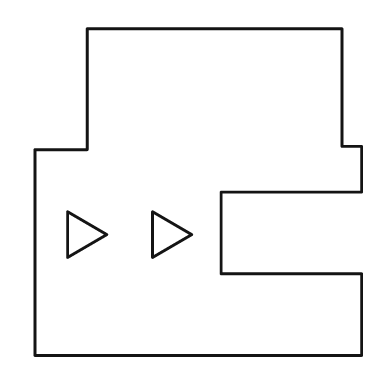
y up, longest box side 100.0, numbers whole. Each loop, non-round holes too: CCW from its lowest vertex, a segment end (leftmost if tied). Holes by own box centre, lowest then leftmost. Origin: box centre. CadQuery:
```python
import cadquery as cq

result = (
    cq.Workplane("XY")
    .moveTo(-50.0, -50.0)
    .lineTo(50.0, -50.0)
    .lineTo(50.0, -25.0)
    .lineTo(7.0, -25.0)
    .lineTo(7.0, 0.0)
    .lineTo(50.0, 0.0)
    .lineTo(50.0, 14.0)
    .lineTo(44.0, 14.0)
    .lineTo(44.0, 50.0)
    .lineTo(-34.0, 50.0)
    .lineTo(-34.0, 13.0)
    .lineTo(-50.0, 13.0)
    .close()
    .moveTo(-40.0, -20.0)
    .lineTo(-28.0, -13.0)
    .lineTo(-40.0, -6.0)
    .close()
    .moveTo(-14.0, -20.0)
    .lineTo(-2.0, -13.0)
    .lineTo(-14.0, -6.0)
    .close()
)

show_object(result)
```